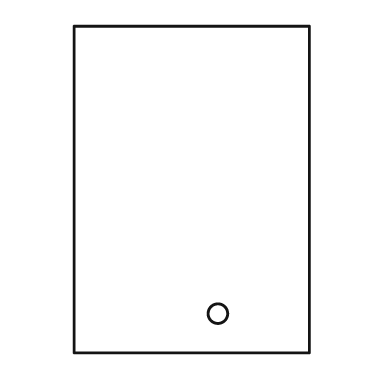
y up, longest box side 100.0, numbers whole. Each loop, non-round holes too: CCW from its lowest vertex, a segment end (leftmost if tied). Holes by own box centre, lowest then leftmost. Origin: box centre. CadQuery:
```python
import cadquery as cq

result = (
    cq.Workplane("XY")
    .moveTo(-36.0, -50.0)
    .lineTo(36.0, -50.0)
    .lineTo(36.0, 50.0)
    .lineTo(-36.0, 50.0)
    .close()
    .moveTo(8.0, -38.0)
    .circle(3.0)
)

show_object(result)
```